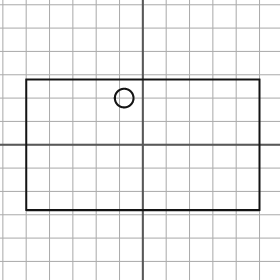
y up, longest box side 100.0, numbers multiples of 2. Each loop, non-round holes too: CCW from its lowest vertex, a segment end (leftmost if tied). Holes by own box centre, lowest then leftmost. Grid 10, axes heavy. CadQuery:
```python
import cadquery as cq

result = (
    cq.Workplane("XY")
    .moveTo(-50.0, -28.0)
    .lineTo(50.0, -28.0)
    .lineTo(50.0, 28.0)
    .lineTo(-50.0, 28.0)
    .close()
    .moveTo(-8.0, 20.0)
    .circle(4.0)
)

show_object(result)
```